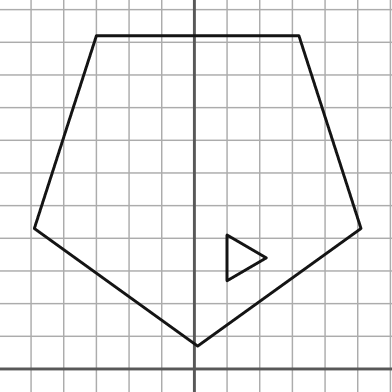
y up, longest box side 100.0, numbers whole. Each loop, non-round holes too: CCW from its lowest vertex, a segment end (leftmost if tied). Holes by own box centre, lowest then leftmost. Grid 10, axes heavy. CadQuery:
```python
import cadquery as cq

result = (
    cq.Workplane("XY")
    .moveTo(1.0, 7.0)
    .lineTo(51.0, 43.0)
    .lineTo(32.0, 102.0)
    .lineTo(-30.0, 102.0)
    .lineTo(-49.0, 43.0)
    .close()
    .moveTo(10.0, 27.0)
    .lineTo(22.0, 34.0)
    .lineTo(10.0, 41.0)
    .close()
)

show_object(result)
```